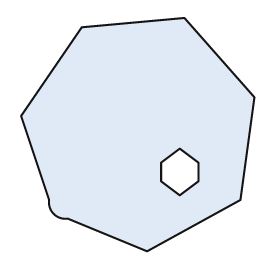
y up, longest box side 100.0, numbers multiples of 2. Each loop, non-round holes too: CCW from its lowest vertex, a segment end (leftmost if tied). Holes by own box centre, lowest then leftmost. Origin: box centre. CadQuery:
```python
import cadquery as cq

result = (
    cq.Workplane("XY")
    .moveTo(4.0, -50.0)
    .lineTo(44.0, -28.0)
    .lineTo(50.0, 16.0)
    .lineTo(20.0, 50.0)
    .lineTo(-24.0, 46.0)
    .lineTo(-50.0, 8.0)
    .lineTo(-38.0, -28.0)
    .threePointArc((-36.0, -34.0), (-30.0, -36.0))
    .close()
    .moveTo(18.0, -26.0)
    .lineTo(26.0, -20.0)
    .lineTo(26.0, -12.0)
    .lineTo(18.0, -6.0)
    .lineTo(10.0, -12.0)
    .lineTo(10.0, -20.0)
    .close()
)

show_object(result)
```